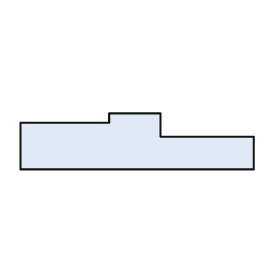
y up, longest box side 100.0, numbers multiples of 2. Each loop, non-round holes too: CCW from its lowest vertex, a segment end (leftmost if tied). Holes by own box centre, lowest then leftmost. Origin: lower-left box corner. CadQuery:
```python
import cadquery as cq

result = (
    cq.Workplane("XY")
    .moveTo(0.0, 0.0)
    .lineTo(100.0, 0.0)
    .lineTo(100.0, 14.0)
    .lineTo(60.0, 14.0)
    .lineTo(60.0, 24.0)
    .lineTo(38.0, 24.0)
    .lineTo(38.0, 20.0)
    .lineTo(0.0, 20.0)
    .close()
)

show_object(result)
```